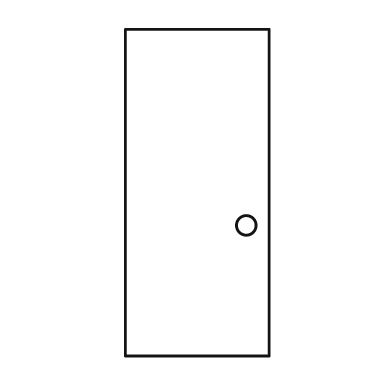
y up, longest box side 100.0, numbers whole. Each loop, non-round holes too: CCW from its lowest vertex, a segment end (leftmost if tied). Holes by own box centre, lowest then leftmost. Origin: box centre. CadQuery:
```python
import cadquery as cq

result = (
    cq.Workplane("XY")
    .moveTo(-22.0, -50.0)
    .lineTo(22.0, -50.0)
    .lineTo(22.0, 50.0)
    .lineTo(-22.0, 50.0)
    .close()
    .moveTo(15.0, -10.0)
    .circle(3.0)
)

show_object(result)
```